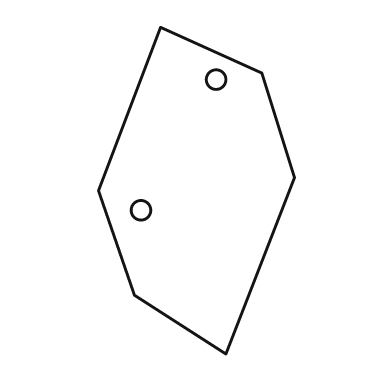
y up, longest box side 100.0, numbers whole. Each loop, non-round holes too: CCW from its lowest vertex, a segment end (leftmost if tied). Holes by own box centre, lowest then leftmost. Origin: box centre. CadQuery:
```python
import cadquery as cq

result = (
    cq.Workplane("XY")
    .moveTo(9.0, -50.0)
    .lineTo(30.0, 4.0)
    .lineTo(20.0, 36.0)
    .lineTo(-11.0, 50.0)
    .lineTo(-30.0, 0.0)
    .lineTo(-19.0, -32.0)
    .close()
    .moveTo(-17.0, -6.0)
    .circle(3.0)
    .moveTo(6.0, 34.0)
    .circle(3.0)
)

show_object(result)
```